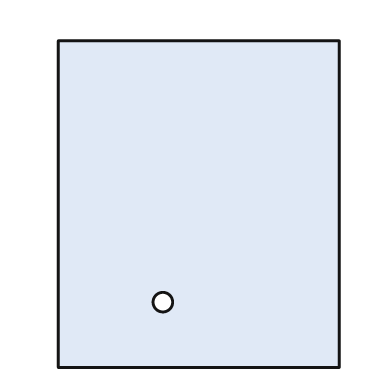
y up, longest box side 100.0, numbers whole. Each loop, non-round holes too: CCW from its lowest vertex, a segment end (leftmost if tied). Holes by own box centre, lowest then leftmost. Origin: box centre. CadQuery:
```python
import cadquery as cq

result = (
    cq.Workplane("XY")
    .moveTo(-43.0, -50.0)
    .lineTo(43.0, -50.0)
    .lineTo(43.0, 50.0)
    .lineTo(-43.0, 50.0)
    .close()
    .moveTo(-11.0, -30.0)
    .circle(3.0)
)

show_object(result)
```